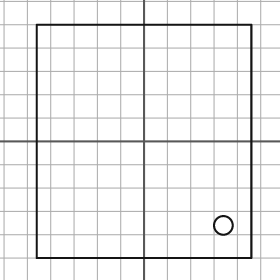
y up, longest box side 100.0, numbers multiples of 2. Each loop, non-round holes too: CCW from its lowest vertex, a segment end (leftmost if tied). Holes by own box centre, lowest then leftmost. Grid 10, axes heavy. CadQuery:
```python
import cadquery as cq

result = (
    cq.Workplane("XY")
    .moveTo(-46.0, -50.0)
    .lineTo(46.0, -50.0)
    .lineTo(46.0, 50.0)
    .lineTo(-46.0, 50.0)
    .close()
    .moveTo(34.0, -36.0)
    .circle(4.0)
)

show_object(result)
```